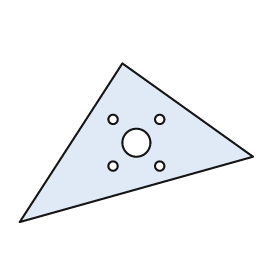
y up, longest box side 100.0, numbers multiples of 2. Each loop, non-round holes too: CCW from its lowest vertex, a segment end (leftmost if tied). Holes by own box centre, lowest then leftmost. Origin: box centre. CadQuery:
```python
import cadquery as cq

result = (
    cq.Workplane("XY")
    .moveTo(-50.0, -34.0)
    .lineTo(50.0, -6.0)
    .lineTo(-6.0, 34.0)
    .close()
    .moveTo(-10.0, -10.0)
    .circle(2.0)
    .moveTo(10.0, -10.0)
    .circle(2.0)
    .moveTo(0.0, 0.0)
    .circle(6.0)
    .moveTo(-10.0, 10.0)
    .circle(2.0)
    .moveTo(10.0, 10.0)
    .circle(2.0)
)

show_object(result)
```